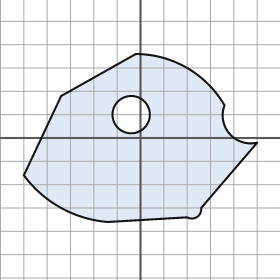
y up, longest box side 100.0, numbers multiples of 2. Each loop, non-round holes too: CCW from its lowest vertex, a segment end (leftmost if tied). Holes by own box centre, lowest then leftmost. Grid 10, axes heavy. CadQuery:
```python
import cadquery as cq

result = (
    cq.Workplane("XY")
    .moveTo(-14.0, -36.0)
    .lineTo(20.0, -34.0)
    .threePointArc((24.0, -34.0), (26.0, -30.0))
    .lineTo(50.0, -2.0)
    .threePointArc((38.0, 2.0), (36.0, 14.0))
    .threePointArc((20.0, 30.0), (-2.0, 36.0))
    .lineTo(-34.0, 18.0)
    .lineTo(-50.0, -16.0)
    .threePointArc((-34.0, -30.0), (-14.0, -36.0))
    .close()
    .moveTo(-4.0, 10.0)
    .circle(8.0)
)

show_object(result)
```